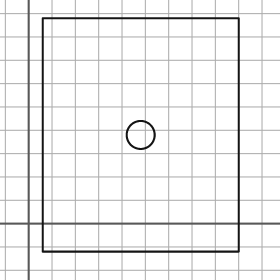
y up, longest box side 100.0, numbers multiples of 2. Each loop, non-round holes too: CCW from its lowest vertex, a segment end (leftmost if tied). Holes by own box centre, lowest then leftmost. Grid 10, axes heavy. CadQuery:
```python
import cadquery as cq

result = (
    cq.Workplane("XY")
    .moveTo(6.0, -12.0)
    .lineTo(90.0, -12.0)
    .lineTo(90.0, 88.0)
    .lineTo(6.0, 88.0)
    .close()
    .moveTo(48.0, 38.0)
    .circle(6.0)
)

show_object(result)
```